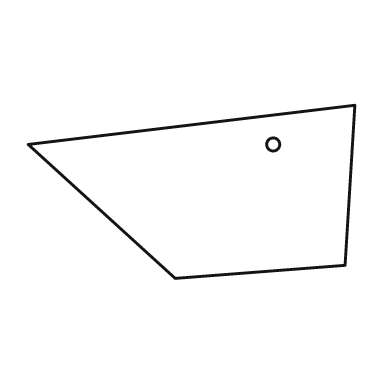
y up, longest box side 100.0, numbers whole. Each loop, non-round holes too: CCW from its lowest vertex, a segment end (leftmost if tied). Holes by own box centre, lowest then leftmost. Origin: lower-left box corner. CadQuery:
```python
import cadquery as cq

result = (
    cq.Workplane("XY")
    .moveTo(45.0, 0.0)
    .lineTo(97.0, 4.0)
    .lineTo(100.0, 53.0)
    .lineTo(0.0, 41.0)
    .close()
    .moveTo(75.0, 41.0)
    .circle(2.0)
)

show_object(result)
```